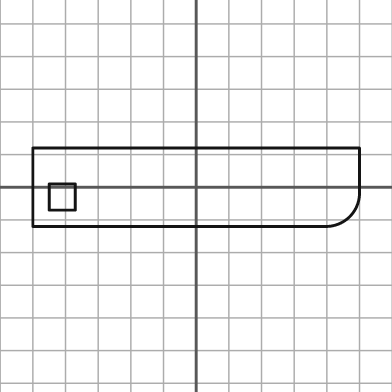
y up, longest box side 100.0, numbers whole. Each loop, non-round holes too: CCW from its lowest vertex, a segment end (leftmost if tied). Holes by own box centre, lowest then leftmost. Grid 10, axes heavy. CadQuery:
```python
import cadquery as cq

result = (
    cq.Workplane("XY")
    .moveTo(-50.0, -12.0)
    .lineTo(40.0, -12.0)
    .threePointArc((47.0, -9.0), (50.0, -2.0))
    .lineTo(50.0, 12.0)
    .lineTo(-50.0, 12.0)
    .close()
    .moveTo(-45.0, -7.0)
    .lineTo(-37.0, -7.0)
    .lineTo(-37.0, 1.0)
    .lineTo(-45.0, 1.0)
    .close()
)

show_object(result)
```